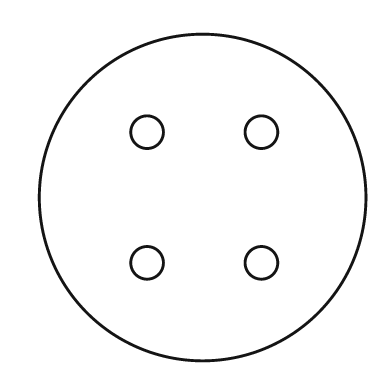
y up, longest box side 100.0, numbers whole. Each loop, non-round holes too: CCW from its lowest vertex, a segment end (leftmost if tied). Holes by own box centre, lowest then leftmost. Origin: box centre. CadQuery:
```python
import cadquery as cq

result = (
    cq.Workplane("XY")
    .moveTo(0.0, 0.0)
    .circle(50.0)
    .moveTo(-17.0, -20.0)
    .circle(5.0)
    .moveTo(18.0, -20.0)
    .circle(5.0)
    .moveTo(-17.0, 20.0)
    .circle(5.0)
    .moveTo(18.0, 20.0)
    .circle(5.0)
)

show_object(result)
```